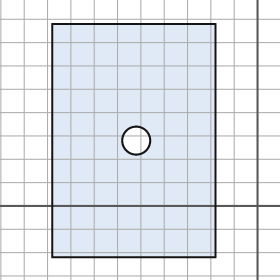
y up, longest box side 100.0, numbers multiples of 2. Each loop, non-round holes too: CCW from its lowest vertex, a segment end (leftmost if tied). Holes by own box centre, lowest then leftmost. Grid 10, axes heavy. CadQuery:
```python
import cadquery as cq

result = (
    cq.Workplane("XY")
    .moveTo(-88.0, -22.0)
    .lineTo(-18.0, -22.0)
    .lineTo(-18.0, 78.0)
    .lineTo(-88.0, 78.0)
    .close()
    .moveTo(-52.0, 28.0)
    .circle(6.0)
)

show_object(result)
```